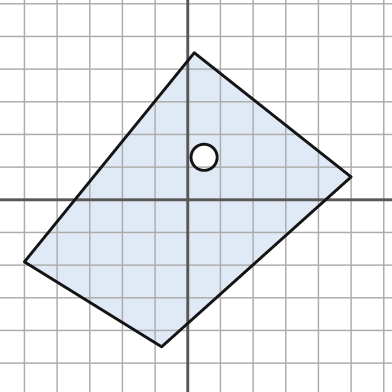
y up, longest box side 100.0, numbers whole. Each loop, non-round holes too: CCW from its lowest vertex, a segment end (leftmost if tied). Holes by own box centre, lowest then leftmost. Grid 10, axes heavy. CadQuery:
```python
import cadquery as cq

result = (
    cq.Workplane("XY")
    .moveTo(-8.0, -45.0)
    .lineTo(50.0, 7.0)
    .lineTo(2.0, 45.0)
    .lineTo(-50.0, -19.0)
    .close()
    .moveTo(5.0, 13.0)
    .circle(4.0)
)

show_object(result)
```